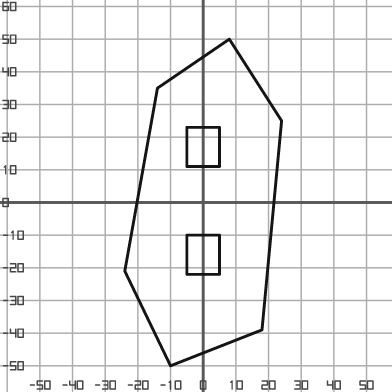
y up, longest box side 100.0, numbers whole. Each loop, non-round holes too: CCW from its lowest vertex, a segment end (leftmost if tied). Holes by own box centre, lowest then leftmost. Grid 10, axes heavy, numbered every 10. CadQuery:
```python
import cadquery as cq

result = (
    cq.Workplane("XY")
    .moveTo(-10.0, -50.0)
    .lineTo(18.0, -39.0)
    .lineTo(24.0, 25.0)
    .lineTo(8.0, 50.0)
    .lineTo(-14.0, 35.0)
    .lineTo(-24.0, -21.0)
    .close()
    .moveTo(-5.0, -22.0)
    .lineTo(5.0, -22.0)
    .lineTo(5.0, -10.0)
    .lineTo(-5.0, -10.0)
    .close()
    .moveTo(-5.0, 11.0)
    .lineTo(5.0, 11.0)
    .lineTo(5.0, 23.0)
    .lineTo(-5.0, 23.0)
    .close()
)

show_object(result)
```